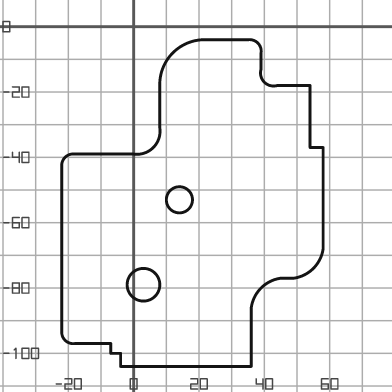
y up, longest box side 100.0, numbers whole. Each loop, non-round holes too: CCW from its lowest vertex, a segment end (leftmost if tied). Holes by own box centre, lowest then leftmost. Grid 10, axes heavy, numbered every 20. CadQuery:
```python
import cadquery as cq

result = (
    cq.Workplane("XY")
    .moveTo(-4.0, -104.0)
    .lineTo(36.0, -104.0)
    .lineTo(36.0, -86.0)
    .threePointArc((39.0, -80.0), (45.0, -77.0))
    .lineTo(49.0, -77.0)
    .threePointArc((55.0, -74.0), (58.0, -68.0))
    .lineTo(58.0, -37.0)
    .lineTo(54.0, -37.0)
    .lineTo(54.0, -18.0)
    .lineTo(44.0, -18.0)
    .threePointArc((40.0, -17.0), (39.0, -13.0))
    .lineTo(39.0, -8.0)
    .threePointArc((38.0, -5.0), (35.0, -4.0))
    .lineTo(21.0, -4.0)
    .threePointArc((12.0, -8.0), (8.0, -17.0))
    .lineTo(8.0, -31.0)
    .threePointArc((6.0, -37.0), (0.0, -39.0))
    .lineTo(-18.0, -39.0)
    .threePointArc((-21.0, -40.0), (-22.0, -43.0))
    .lineTo(-22.0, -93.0)
    .threePointArc((-21.0, -96.0), (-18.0, -97.0))
    .lineTo(-7.0, -97.0)
    .lineTo(-7.0, -100.0)
    .lineTo(-4.0, -100.0)
    .close()
    .moveTo(3.0, -79.0)
    .circle(5.0)
    .moveTo(14.0, -53.0)
    .circle(4.0)
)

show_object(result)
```